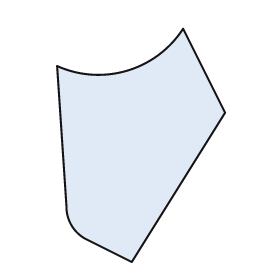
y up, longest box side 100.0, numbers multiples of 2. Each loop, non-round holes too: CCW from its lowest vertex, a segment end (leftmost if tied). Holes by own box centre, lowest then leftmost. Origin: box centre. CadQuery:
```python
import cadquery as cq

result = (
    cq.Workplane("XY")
    .moveTo(-4.0, -50.0)
    .lineTo(36.0, 14.0)
    .lineTo(18.0, 50.0)
    .threePointArc((-6.0, 32.0), (-36.0, 34.0))
    .lineTo(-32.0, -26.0)
    .threePointArc((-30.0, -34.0), (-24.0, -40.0))
    .close()
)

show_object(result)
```